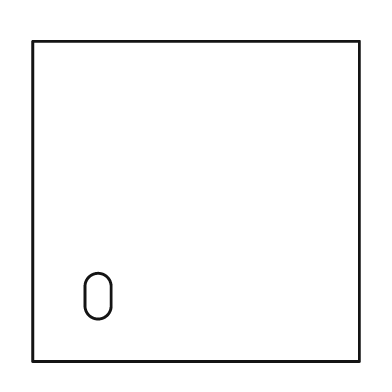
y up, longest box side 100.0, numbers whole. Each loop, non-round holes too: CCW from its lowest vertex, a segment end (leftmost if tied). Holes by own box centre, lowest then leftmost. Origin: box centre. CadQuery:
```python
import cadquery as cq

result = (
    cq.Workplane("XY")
    .moveTo(-50.0, -49.0)
    .lineTo(50.0, -49.0)
    .lineTo(50.0, 49.0)
    .lineTo(-50.0, 49.0)
    .close()
    .moveTo(-34.0, -32.0)
    .threePointArc((-30.0, -36.0), (-26.0, -32.0))
    .lineTo(-26.0, -26.0)
    .threePointArc((-30.0, -22.0), (-34.0, -26.0))
    .close()
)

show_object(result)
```